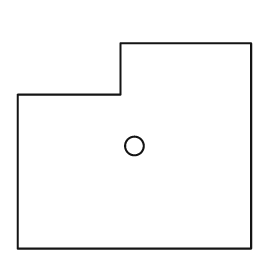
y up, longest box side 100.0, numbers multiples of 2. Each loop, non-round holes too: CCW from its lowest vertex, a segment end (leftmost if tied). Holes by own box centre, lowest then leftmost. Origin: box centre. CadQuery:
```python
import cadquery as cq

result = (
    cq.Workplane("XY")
    .moveTo(-50.0, -44.0)
    .lineTo(50.0, -44.0)
    .lineTo(50.0, 44.0)
    .lineTo(-6.0, 44.0)
    .lineTo(-6.0, 22.0)
    .lineTo(-50.0, 22.0)
    .close()
    .moveTo(0.0, 0.0)
    .circle(4.0)
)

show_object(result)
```